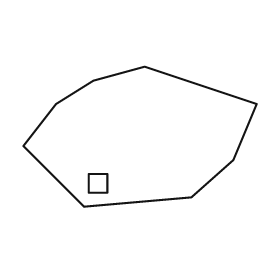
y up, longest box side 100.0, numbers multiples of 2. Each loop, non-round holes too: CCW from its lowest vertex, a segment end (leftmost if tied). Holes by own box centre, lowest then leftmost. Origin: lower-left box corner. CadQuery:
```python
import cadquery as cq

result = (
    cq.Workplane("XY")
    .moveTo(26.0, 0.0)
    .lineTo(72.0, 4.0)
    .lineTo(90.0, 20.0)
    .lineTo(100.0, 44.0)
    .lineTo(52.0, 60.0)
    .lineTo(30.0, 54.0)
    .lineTo(14.0, 44.0)
    .lineTo(0.0, 26.0)
    .close()
    .moveTo(28.0, 6.0)
    .lineTo(36.0, 6.0)
    .lineTo(36.0, 14.0)
    .lineTo(28.0, 14.0)
    .close()
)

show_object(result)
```